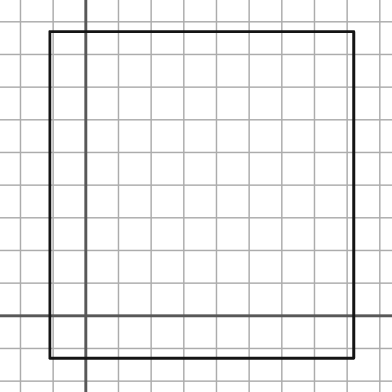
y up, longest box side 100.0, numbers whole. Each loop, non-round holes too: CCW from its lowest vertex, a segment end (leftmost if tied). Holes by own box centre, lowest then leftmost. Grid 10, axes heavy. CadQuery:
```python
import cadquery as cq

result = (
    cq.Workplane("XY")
    .moveTo(-11.0, -13.0)
    .lineTo(82.0, -13.0)
    .lineTo(82.0, 87.0)
    .lineTo(-11.0, 87.0)
    .close()
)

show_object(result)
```